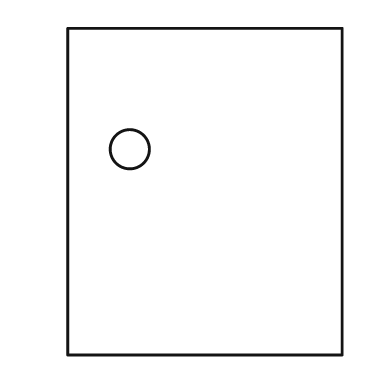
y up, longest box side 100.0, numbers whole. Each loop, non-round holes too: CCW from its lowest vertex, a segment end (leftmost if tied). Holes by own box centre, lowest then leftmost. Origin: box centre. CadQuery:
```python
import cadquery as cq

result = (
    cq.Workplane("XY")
    .moveTo(-42.0, -50.0)
    .lineTo(42.0, -50.0)
    .lineTo(42.0, 50.0)
    .lineTo(-42.0, 50.0)
    .close()
    .moveTo(-23.0, 13.0)
    .circle(6.0)
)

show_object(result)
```